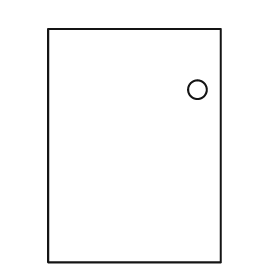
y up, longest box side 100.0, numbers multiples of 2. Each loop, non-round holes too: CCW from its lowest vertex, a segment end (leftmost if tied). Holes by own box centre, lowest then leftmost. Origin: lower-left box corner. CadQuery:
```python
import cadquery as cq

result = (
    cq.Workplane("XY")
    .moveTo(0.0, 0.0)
    .lineTo(74.0, 0.0)
    .lineTo(74.0, 100.0)
    .lineTo(0.0, 100.0)
    .close()
    .moveTo(64.0, 74.0)
    .circle(4.0)
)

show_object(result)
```